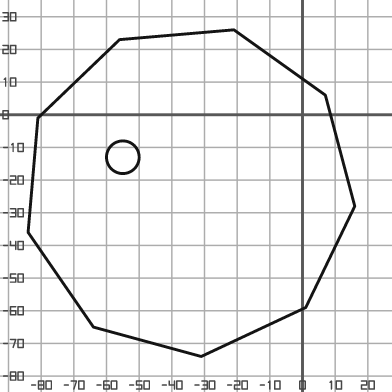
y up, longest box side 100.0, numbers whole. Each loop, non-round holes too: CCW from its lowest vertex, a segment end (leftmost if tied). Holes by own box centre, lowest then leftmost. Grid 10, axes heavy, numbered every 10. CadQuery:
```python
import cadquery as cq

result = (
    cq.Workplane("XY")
    .moveTo(-31.0, -74.0)
    .lineTo(1.0, -59.0)
    .lineTo(16.0, -28.0)
    .lineTo(7.0, 6.0)
    .lineTo(-21.0, 26.0)
    .lineTo(-56.0, 23.0)
    .lineTo(-81.0, -1.0)
    .lineTo(-84.0, -36.0)
    .lineTo(-64.0, -65.0)
    .close()
    .moveTo(-55.0, -13.0)
    .circle(5.0)
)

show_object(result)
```